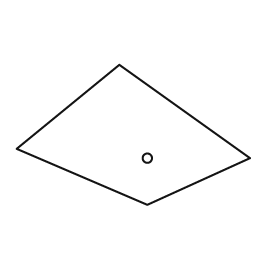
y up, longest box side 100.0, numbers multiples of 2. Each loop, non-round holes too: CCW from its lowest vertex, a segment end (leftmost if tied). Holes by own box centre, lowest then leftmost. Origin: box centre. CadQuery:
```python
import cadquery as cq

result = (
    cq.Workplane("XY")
    .moveTo(6.0, -30.0)
    .lineTo(50.0, -10.0)
    .lineTo(-6.0, 30.0)
    .lineTo(-50.0, -6.0)
    .close()
    .moveTo(6.0, -10.0)
    .circle(2.0)
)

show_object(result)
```